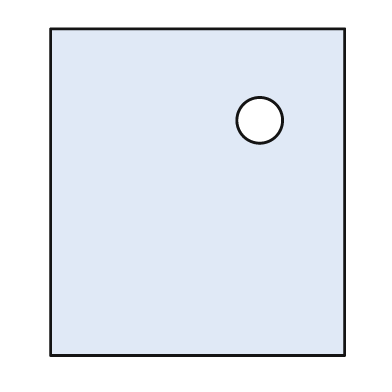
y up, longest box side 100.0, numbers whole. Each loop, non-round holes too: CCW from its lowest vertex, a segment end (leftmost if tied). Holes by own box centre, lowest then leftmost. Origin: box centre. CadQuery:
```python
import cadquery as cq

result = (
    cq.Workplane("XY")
    .moveTo(-45.0, -50.0)
    .lineTo(45.0, -50.0)
    .lineTo(45.0, 50.0)
    .lineTo(-45.0, 50.0)
    .close()
    .moveTo(19.0, 22.0)
    .circle(7.0)
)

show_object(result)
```